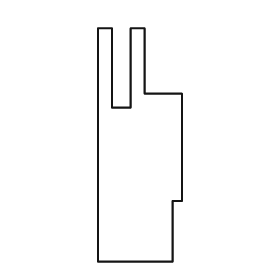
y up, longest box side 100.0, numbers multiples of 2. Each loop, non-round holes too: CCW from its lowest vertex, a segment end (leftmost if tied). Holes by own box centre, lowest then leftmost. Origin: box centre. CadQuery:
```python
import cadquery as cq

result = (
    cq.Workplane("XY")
    .moveTo(-18.0, -50.0)
    .lineTo(14.0, -50.0)
    .lineTo(14.0, -24.0)
    .lineTo(18.0, -24.0)
    .lineTo(18.0, 22.0)
    .lineTo(2.0, 22.0)
    .lineTo(2.0, 50.0)
    .lineTo(-4.0, 50.0)
    .lineTo(-4.0, 16.0)
    .lineTo(-12.0, 16.0)
    .lineTo(-12.0, 50.0)
    .lineTo(-18.0, 50.0)
    .close()
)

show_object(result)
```